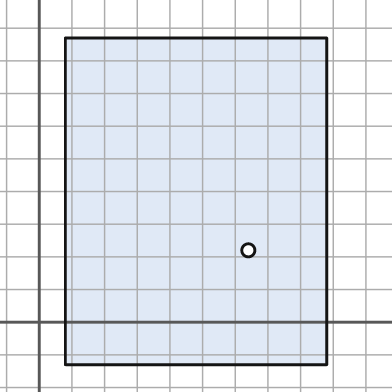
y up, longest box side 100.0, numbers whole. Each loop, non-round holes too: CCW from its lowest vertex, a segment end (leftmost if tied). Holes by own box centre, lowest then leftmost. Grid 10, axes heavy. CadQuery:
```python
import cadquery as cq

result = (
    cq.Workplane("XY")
    .moveTo(8.0, -13.0)
    .lineTo(88.0, -13.0)
    .lineTo(88.0, 87.0)
    .lineTo(8.0, 87.0)
    .close()
    .moveTo(64.0, 22.0)
    .circle(2.0)
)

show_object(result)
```